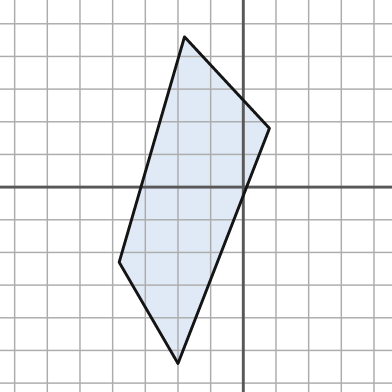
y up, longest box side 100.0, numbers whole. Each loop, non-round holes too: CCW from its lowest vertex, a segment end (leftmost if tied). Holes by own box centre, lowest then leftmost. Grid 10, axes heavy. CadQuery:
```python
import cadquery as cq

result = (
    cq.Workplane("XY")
    .moveTo(-20.0, -54.0)
    .lineTo(8.0, 18.0)
    .lineTo(-18.0, 46.0)
    .lineTo(-38.0, -23.0)
    .close()
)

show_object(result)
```